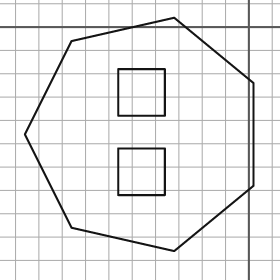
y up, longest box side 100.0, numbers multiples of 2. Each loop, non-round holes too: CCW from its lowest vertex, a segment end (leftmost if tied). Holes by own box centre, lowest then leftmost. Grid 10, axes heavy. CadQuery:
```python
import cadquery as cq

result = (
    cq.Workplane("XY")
    .moveTo(-32.0, -96.0)
    .lineTo(2.0, -68.0)
    .lineTo(2.0, -24.0)
    .lineTo(-32.0, 4.0)
    .lineTo(-76.0, -6.0)
    .lineTo(-96.0, -46.0)
    .lineTo(-76.0, -86.0)
    .close()
    .moveTo(-56.0, -72.0)
    .lineTo(-36.0, -72.0)
    .lineTo(-36.0, -52.0)
    .lineTo(-56.0, -52.0)
    .close()
    .moveTo(-56.0, -38.0)
    .lineTo(-36.0, -38.0)
    .lineTo(-36.0, -18.0)
    .lineTo(-56.0, -18.0)
    .close()
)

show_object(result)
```